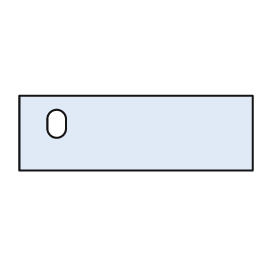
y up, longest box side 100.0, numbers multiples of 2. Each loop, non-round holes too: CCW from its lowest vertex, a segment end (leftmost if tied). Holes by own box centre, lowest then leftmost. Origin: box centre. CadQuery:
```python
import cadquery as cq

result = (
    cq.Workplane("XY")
    .moveTo(-50.0, -16.0)
    .lineTo(50.0, -16.0)
    .lineTo(50.0, 16.0)
    .lineTo(-50.0, 16.0)
    .close()
    .moveTo(-38.0, 2.0)
    .threePointArc((-34.0, -2.0), (-30.0, 2.0))
    .lineTo(-30.0, 6.0)
    .threePointArc((-34.0, 10.0), (-38.0, 6.0))
    .close()
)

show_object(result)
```